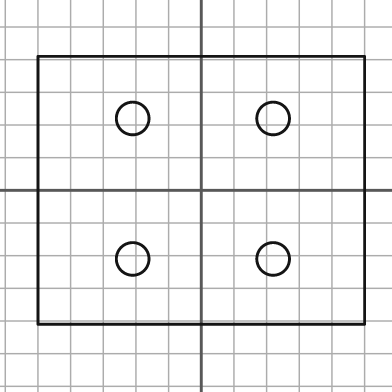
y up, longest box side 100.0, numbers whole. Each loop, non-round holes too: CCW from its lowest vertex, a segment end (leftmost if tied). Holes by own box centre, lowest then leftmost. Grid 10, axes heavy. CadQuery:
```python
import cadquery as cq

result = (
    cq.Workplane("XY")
    .moveTo(-50.0, -41.0)
    .lineTo(50.0, -41.0)
    .lineTo(50.0, 41.0)
    .lineTo(-50.0, 41.0)
    .close()
    .moveTo(-21.0, -21.0)
    .circle(5.0)
    .moveTo(22.0, -21.0)
    .circle(5.0)
    .moveTo(-21.0, 22.0)
    .circle(5.0)
    .moveTo(22.0, 22.0)
    .circle(5.0)
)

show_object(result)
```